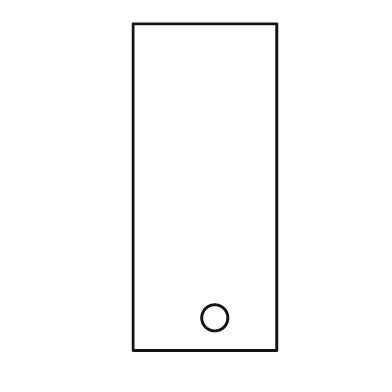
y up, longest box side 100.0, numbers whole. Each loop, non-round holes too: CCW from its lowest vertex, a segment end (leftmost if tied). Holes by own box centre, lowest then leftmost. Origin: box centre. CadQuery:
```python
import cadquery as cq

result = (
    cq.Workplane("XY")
    .moveTo(-22.0, -50.0)
    .lineTo(22.0, -50.0)
    .lineTo(22.0, 50.0)
    .lineTo(-22.0, 50.0)
    .close()
    .moveTo(3.0, -40.0)
    .circle(4.0)
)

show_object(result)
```